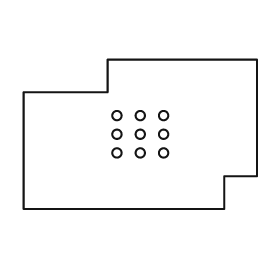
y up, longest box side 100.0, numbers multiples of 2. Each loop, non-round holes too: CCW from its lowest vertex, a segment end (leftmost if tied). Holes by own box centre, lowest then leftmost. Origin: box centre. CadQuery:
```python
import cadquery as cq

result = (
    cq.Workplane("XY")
    .moveTo(-50.0, -32.0)
    .lineTo(36.0, -32.0)
    .lineTo(36.0, -18.0)
    .lineTo(50.0, -18.0)
    .lineTo(50.0, 32.0)
    .lineTo(-14.0, 32.0)
    .lineTo(-14.0, 18.0)
    .lineTo(-50.0, 18.0)
    .close()
    .moveTo(-10.0, -8.0)
    .circle(2.0)
    .moveTo(0.0, -8.0)
    .circle(2.0)
    .moveTo(10.0, -8.0)
    .circle(2.0)
    .moveTo(-10.0, 0.0)
    .circle(2.0)
    .moveTo(0.0, 0.0)
    .circle(2.0)
    .moveTo(10.0, 0.0)
    .circle(2.0)
    .moveTo(-10.0, 8.0)
    .circle(2.0)
    .moveTo(0.0, 8.0)
    .circle(2.0)
    .moveTo(10.0, 8.0)
    .circle(2.0)
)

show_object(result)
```